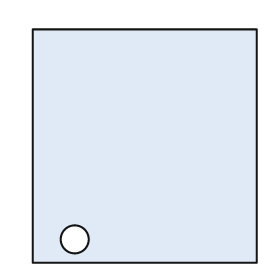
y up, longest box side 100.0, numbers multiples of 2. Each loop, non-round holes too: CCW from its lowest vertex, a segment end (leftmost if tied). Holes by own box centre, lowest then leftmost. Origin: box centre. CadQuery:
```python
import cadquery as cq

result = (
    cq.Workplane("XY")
    .moveTo(-48.0, -50.0)
    .lineTo(48.0, -50.0)
    .lineTo(48.0, 50.0)
    .lineTo(-48.0, 50.0)
    .close()
    .moveTo(-30.0, -40.0)
    .circle(6.0)
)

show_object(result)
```